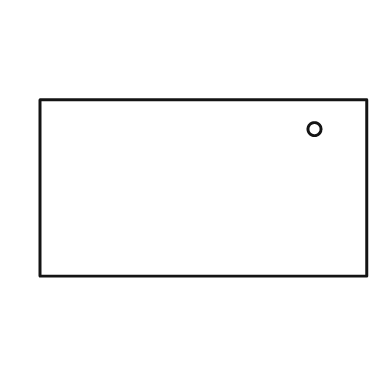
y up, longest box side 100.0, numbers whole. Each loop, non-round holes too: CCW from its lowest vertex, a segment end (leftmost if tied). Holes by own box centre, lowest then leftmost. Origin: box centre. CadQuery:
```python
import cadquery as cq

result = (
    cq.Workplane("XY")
    .moveTo(-50.0, -27.0)
    .lineTo(50.0, -27.0)
    .lineTo(50.0, 27.0)
    .lineTo(-50.0, 27.0)
    .close()
    .moveTo(34.0, 18.0)
    .circle(2.0)
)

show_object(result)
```